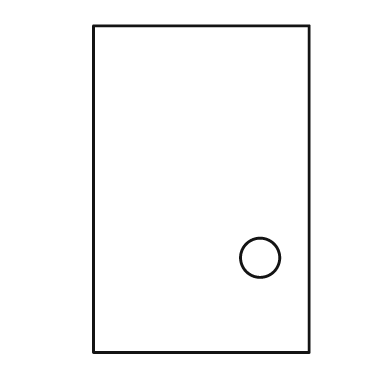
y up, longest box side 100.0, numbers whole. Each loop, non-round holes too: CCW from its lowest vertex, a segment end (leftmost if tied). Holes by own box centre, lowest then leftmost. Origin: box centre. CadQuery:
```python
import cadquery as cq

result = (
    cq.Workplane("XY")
    .moveTo(-33.0, -50.0)
    .lineTo(33.0, -50.0)
    .lineTo(33.0, 50.0)
    .lineTo(-33.0, 50.0)
    .close()
    .moveTo(18.0, -21.0)
    .circle(6.0)
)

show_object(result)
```